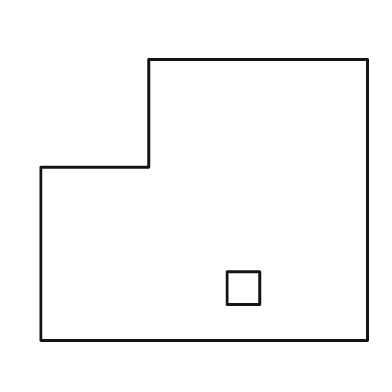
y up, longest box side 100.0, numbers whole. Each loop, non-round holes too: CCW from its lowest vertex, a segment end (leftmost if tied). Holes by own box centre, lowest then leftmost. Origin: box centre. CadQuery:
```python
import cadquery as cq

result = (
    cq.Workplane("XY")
    .moveTo(-50.0, -43.0)
    .lineTo(50.0, -43.0)
    .lineTo(50.0, 43.0)
    .lineTo(-17.0, 43.0)
    .lineTo(-17.0, 10.0)
    .lineTo(-50.0, 10.0)
    .close()
    .moveTo(7.0, -32.0)
    .lineTo(17.0, -32.0)
    .lineTo(17.0, -22.0)
    .lineTo(7.0, -22.0)
    .close()
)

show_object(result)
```